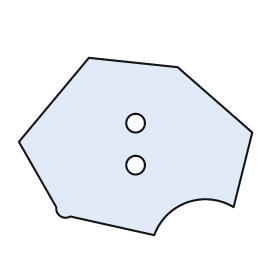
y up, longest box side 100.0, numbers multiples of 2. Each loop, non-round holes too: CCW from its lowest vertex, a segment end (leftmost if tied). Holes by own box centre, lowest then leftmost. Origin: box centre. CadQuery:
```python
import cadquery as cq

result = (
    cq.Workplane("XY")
    .moveTo(8.0, -38.0)
    .threePointArc((22.0, -24.0), (42.0, -26.0))
    .lineTo(50.0, 6.0)
    .lineTo(18.0, 34.0)
    .lineTo(-20.0, 38.0)
    .lineTo(-50.0, 2.0)
    .lineTo(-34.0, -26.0)
    .threePointArc((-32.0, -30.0), (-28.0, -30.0))
    .close()
    .moveTo(0.0, -8.0)
    .circle(4.0)
    .moveTo(0.0, 10.0)
    .circle(4.0)
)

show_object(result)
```